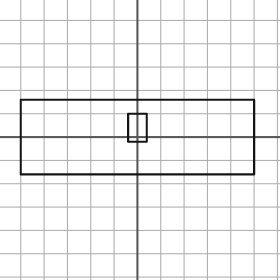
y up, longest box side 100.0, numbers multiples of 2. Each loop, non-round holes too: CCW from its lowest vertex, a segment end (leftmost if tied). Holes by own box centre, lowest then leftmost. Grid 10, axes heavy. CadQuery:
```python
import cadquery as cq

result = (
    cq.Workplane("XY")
    .moveTo(-50.0, -16.0)
    .lineTo(50.0, -16.0)
    .lineTo(50.0, 16.0)
    .lineTo(-50.0, 16.0)
    .close()
    .moveTo(-4.0, -2.0)
    .lineTo(4.0, -2.0)
    .lineTo(4.0, 10.0)
    .lineTo(-4.0, 10.0)
    .close()
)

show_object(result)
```